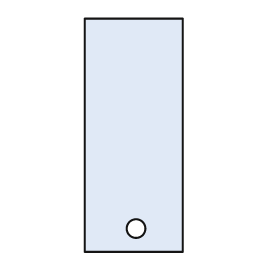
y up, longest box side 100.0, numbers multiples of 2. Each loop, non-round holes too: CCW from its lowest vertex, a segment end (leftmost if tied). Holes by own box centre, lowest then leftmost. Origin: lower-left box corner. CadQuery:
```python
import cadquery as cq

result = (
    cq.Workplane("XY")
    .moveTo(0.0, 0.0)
    .lineTo(42.0, 0.0)
    .lineTo(42.0, 100.0)
    .lineTo(0.0, 100.0)
    .close()
    .moveTo(22.0, 10.0)
    .circle(4.0)
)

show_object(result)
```